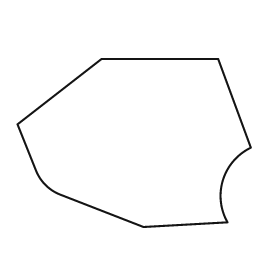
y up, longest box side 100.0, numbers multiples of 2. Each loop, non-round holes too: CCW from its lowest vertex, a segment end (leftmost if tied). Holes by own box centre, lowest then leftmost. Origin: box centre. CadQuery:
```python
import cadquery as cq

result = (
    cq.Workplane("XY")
    .moveTo(4.0, -36.0)
    .lineTo(40.0, -34.0)
    .threePointArc((38.0, -16.0), (50.0, -2.0))
    .lineTo(36.0, 36.0)
    .lineTo(-14.0, 36.0)
    .lineTo(-50.0, 8.0)
    .lineTo(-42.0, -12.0)
    .threePointArc((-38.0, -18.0), (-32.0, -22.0))
    .close()
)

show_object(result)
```